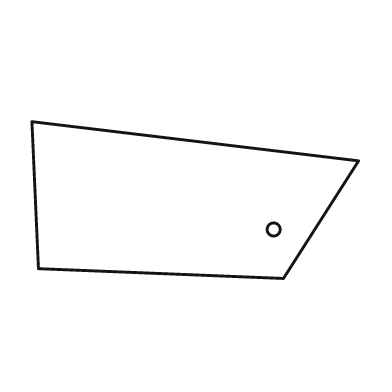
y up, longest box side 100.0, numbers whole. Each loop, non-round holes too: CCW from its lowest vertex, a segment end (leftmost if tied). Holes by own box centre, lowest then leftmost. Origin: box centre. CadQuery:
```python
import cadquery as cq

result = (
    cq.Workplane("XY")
    .moveTo(27.0, -24.0)
    .lineTo(50.0, 12.0)
    .lineTo(-50.0, 24.0)
    .lineTo(-48.0, -21.0)
    .close()
    .moveTo(24.0, -9.0)
    .circle(2.0)
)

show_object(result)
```